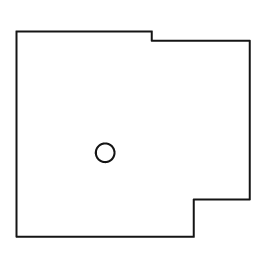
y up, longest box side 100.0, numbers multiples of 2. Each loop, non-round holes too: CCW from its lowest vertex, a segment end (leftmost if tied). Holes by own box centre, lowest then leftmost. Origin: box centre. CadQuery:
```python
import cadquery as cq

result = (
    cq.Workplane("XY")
    .moveTo(-50.0, -44.0)
    .lineTo(26.0, -44.0)
    .lineTo(26.0, -28.0)
    .lineTo(50.0, -28.0)
    .lineTo(50.0, 40.0)
    .lineTo(8.0, 40.0)
    .lineTo(8.0, 44.0)
    .lineTo(-50.0, 44.0)
    .close()
    .moveTo(-12.0, -8.0)
    .circle(4.0)
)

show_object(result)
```